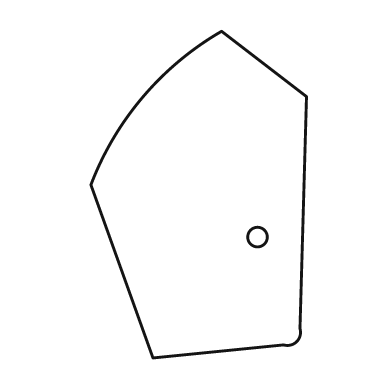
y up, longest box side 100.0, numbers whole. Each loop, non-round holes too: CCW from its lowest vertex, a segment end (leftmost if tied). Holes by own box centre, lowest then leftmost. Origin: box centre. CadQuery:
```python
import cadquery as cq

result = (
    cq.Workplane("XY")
    .moveTo(-14.0, -50.0)
    .lineTo(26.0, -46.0)
    .threePointArc((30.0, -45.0), (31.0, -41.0))
    .lineTo(33.0, 30.0)
    .lineTo(7.0, 50.0)
    .threePointArc((-17.0, 30.0), (-33.0, 3.0))
    .close()
    .moveTo(18.0, -13.0)
    .circle(3.0)
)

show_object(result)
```